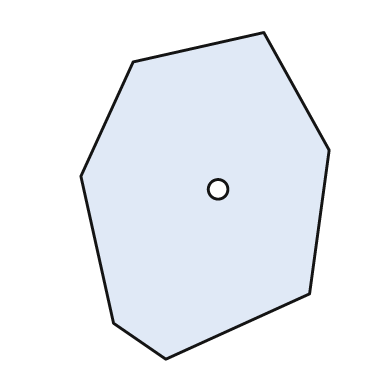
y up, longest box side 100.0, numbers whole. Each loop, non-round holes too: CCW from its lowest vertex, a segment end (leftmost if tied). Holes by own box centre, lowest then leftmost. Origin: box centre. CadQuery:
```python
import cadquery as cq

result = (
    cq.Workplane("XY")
    .moveTo(-12.0, -50.0)
    .lineTo(32.0, -30.0)
    .lineTo(38.0, 14.0)
    .lineTo(18.0, 50.0)
    .lineTo(-22.0, 41.0)
    .lineTo(-38.0, 6.0)
    .lineTo(-28.0, -39.0)
    .close()
    .moveTo(4.0, 2.0)
    .circle(3.0)
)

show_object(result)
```